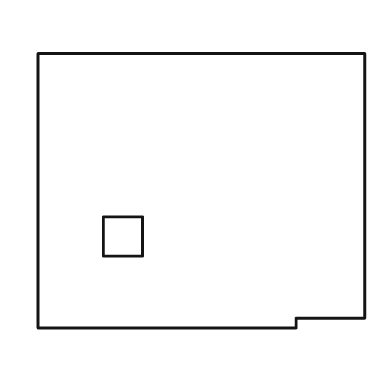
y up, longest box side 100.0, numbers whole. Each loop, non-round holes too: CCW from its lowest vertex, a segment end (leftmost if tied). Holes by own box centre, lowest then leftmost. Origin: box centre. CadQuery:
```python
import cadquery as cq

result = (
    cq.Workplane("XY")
    .moveTo(-50.0, -42.0)
    .lineTo(29.0, -42.0)
    .lineTo(29.0, -39.0)
    .lineTo(50.0, -39.0)
    .lineTo(50.0, 42.0)
    .lineTo(-50.0, 42.0)
    .close()
    .moveTo(-30.0, -20.0)
    .lineTo(-18.0, -20.0)
    .lineTo(-18.0, -8.0)
    .lineTo(-30.0, -8.0)
    .close()
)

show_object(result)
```